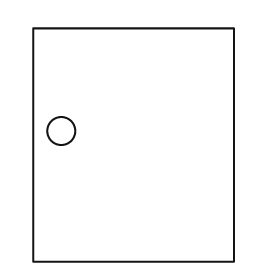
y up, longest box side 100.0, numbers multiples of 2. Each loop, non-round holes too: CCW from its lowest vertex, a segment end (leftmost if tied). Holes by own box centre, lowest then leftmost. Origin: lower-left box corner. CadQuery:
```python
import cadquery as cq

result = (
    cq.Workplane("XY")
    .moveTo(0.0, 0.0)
    .lineTo(86.0, 0.0)
    .lineTo(86.0, 100.0)
    .lineTo(0.0, 100.0)
    .close()
    .moveTo(12.0, 56.0)
    .circle(6.0)
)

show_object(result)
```